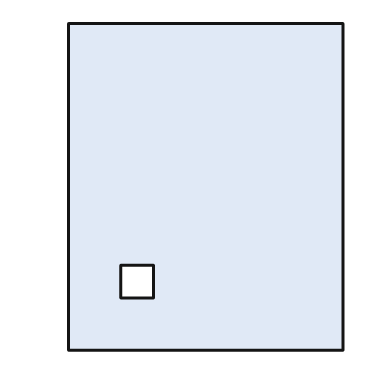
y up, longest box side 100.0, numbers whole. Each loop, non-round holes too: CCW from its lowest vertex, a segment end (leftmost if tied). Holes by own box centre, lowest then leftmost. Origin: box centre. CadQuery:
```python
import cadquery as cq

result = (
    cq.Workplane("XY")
    .moveTo(-42.0, -50.0)
    .lineTo(42.0, -50.0)
    .lineTo(42.0, 50.0)
    .lineTo(-42.0, 50.0)
    .close()
    .moveTo(-26.0, -34.0)
    .lineTo(-16.0, -34.0)
    .lineTo(-16.0, -24.0)
    .lineTo(-26.0, -24.0)
    .close()
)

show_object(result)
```